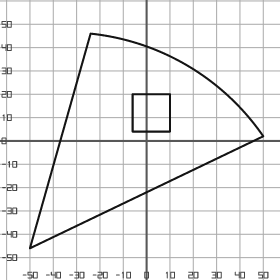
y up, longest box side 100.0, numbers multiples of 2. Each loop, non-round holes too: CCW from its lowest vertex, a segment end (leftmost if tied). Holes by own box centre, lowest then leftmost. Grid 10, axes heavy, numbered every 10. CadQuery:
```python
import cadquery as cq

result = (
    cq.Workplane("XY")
    .moveTo(-50.0, -46.0)
    .lineTo(50.0, 2.0)
    .threePointArc((18.0, 32.0), (-24.0, 46.0))
    .close()
    .moveTo(-6.0, 4.0)
    .lineTo(10.0, 4.0)
    .lineTo(10.0, 20.0)
    .lineTo(-6.0, 20.0)
    .close()
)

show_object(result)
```